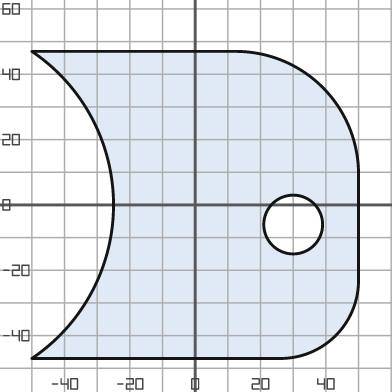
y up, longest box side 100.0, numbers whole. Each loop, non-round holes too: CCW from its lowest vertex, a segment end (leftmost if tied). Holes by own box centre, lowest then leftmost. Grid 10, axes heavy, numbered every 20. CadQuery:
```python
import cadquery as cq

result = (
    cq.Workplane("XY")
    .moveTo(-50.0, -47.0)
    .lineTo(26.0, -47.0)
    .threePointArc((43.0, -40.0), (50.0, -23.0))
    .lineTo(50.0, 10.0)
    .threePointArc((39.0, 36.0), (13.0, 47.0))
    .lineTo(-50.0, 47.0)
    .threePointArc((-25.0, 0.0), (-50.0, -47.0))
    .close()
    .moveTo(30.0, -6.0)
    .circle(9.0)
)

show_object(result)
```